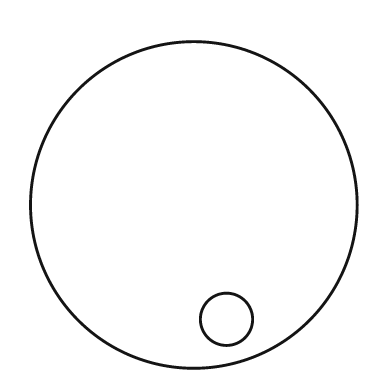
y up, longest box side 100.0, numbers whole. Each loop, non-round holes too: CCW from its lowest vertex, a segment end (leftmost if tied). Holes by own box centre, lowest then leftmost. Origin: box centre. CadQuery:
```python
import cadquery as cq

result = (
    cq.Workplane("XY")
    .moveTo(0.0, 0.0)
    .circle(50.0)
    .moveTo(10.0, -35.0)
    .circle(8.0)
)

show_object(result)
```